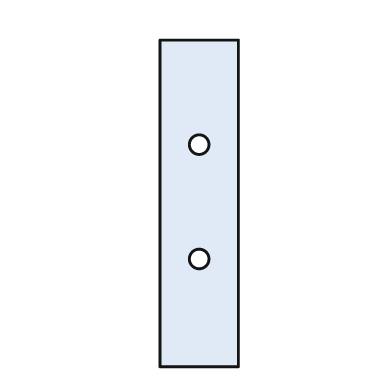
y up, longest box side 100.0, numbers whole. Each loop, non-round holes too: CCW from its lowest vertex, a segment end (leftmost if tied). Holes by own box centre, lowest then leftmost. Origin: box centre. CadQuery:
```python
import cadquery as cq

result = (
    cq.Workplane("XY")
    .moveTo(-12.0, -50.0)
    .lineTo(12.0, -50.0)
    .lineTo(12.0, 50.0)
    .lineTo(-12.0, 50.0)
    .close()
    .moveTo(0.0, -17.0)
    .circle(3.0)
    .moveTo(0.0, 18.0)
    .circle(3.0)
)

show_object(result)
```